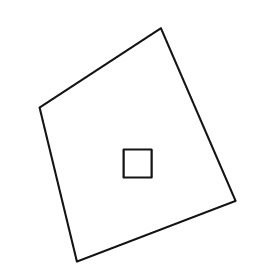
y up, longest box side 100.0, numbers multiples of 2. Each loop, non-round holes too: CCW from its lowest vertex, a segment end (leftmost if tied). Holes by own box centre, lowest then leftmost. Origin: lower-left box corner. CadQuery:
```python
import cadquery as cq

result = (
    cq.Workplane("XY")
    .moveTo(16.0, 0.0)
    .lineTo(84.0, 26.0)
    .lineTo(52.0, 100.0)
    .lineTo(0.0, 66.0)
    .close()
    .moveTo(36.0, 36.0)
    .lineTo(48.0, 36.0)
    .lineTo(48.0, 48.0)
    .lineTo(36.0, 48.0)
    .close()
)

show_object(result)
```